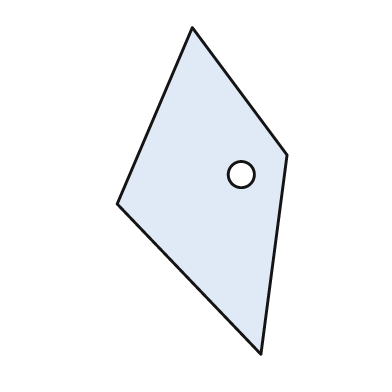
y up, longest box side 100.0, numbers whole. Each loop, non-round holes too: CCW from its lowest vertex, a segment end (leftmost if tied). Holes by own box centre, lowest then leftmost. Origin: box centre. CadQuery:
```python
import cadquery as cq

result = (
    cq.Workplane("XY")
    .moveTo(18.0, -50.0)
    .lineTo(26.0, 11.0)
    .lineTo(-3.0, 50.0)
    .lineTo(-26.0, -4.0)
    .close()
    .moveTo(12.0, 5.0)
    .circle(4.0)
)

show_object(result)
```